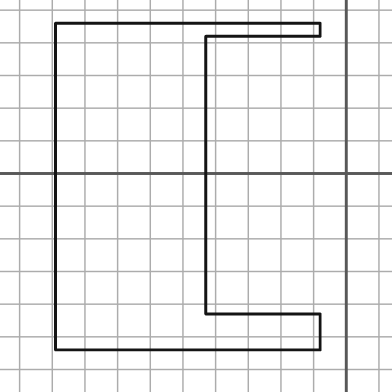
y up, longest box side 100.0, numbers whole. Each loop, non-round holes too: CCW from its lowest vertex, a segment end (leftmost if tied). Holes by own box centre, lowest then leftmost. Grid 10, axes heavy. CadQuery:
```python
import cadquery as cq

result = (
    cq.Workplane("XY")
    .moveTo(-89.0, -54.0)
    .lineTo(-8.0, -54.0)
    .lineTo(-8.0, -43.0)
    .lineTo(-43.0, -43.0)
    .lineTo(-43.0, 42.0)
    .lineTo(-8.0, 42.0)
    .lineTo(-8.0, 46.0)
    .lineTo(-89.0, 46.0)
    .close()
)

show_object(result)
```